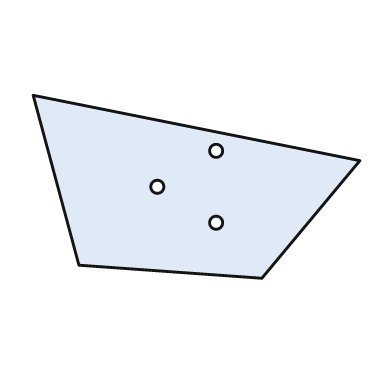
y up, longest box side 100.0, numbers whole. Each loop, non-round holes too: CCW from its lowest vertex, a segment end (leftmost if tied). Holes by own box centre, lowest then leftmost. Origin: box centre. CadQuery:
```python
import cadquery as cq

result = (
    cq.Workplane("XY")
    .moveTo(20.0, -28.0)
    .lineTo(50.0, 8.0)
    .lineTo(-50.0, 28.0)
    .lineTo(-36.0, -24.0)
    .close()
    .moveTo(6.0, -11.0)
    .circle(2.0)
    .moveTo(-12.0, 0.0)
    .circle(2.0)
    .moveTo(6.0, 11.0)
    .circle(2.0)
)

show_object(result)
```